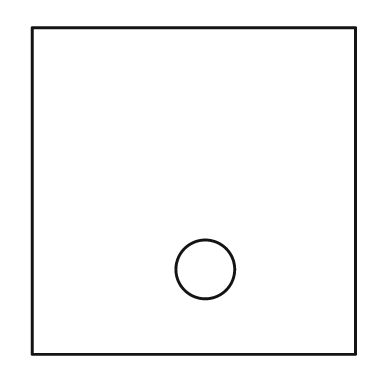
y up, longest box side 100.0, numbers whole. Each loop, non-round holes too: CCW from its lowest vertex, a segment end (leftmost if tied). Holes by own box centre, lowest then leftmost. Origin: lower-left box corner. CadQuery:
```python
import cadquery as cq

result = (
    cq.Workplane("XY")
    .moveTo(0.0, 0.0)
    .lineTo(99.0, 0.0)
    .lineTo(99.0, 100.0)
    .lineTo(0.0, 100.0)
    .close()
    .moveTo(53.0, 26.0)
    .circle(9.0)
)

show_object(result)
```